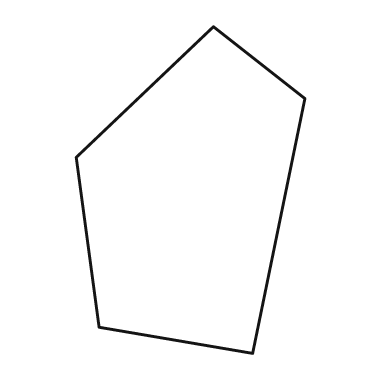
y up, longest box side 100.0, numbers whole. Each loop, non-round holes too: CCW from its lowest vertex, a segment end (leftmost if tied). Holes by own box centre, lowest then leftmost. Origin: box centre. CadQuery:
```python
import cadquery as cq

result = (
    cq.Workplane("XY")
    .moveTo(19.0, -50.0)
    .lineTo(35.0, 28.0)
    .lineTo(7.0, 50.0)
    .lineTo(-35.0, 10.0)
    .lineTo(-28.0, -42.0)
    .close()
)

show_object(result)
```